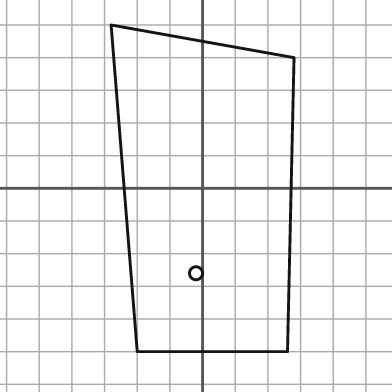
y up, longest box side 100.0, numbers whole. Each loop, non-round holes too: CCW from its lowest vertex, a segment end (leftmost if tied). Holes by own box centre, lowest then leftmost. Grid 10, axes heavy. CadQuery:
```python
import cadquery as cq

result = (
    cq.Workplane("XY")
    .moveTo(-20.0, -50.0)
    .lineTo(26.0, -50.0)
    .lineTo(28.0, 40.0)
    .lineTo(-28.0, 50.0)
    .close()
    .moveTo(-2.0, -26.0)
    .circle(2.0)
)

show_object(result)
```